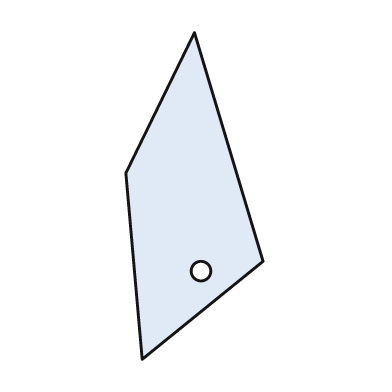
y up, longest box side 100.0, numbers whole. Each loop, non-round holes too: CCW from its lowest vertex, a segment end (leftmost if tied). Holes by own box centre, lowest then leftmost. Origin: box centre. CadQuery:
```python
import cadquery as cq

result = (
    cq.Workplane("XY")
    .moveTo(-16.0, -50.0)
    .lineTo(21.0, -20.0)
    .lineTo(0.0, 50.0)
    .lineTo(-21.0, 7.0)
    .close()
    .moveTo(2.0, -23.0)
    .circle(3.0)
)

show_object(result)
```